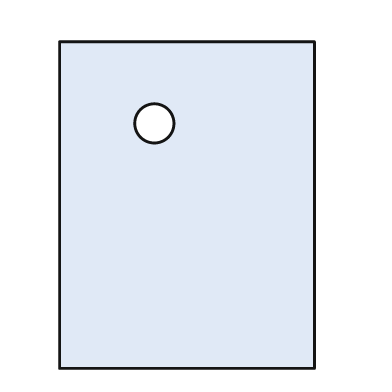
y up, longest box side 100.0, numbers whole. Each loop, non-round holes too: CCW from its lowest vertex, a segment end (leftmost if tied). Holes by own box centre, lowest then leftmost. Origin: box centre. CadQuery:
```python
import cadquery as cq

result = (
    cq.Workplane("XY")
    .moveTo(-39.0, -50.0)
    .lineTo(39.0, -50.0)
    .lineTo(39.0, 50.0)
    .lineTo(-39.0, 50.0)
    .close()
    .moveTo(-10.0, 25.0)
    .circle(6.0)
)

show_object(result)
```